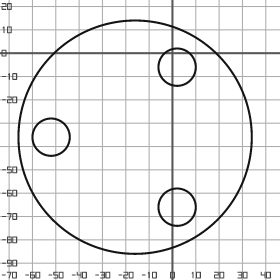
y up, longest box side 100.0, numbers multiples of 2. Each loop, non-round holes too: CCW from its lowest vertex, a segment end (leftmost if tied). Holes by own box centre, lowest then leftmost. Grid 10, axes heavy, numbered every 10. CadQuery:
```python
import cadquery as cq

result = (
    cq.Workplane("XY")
    .moveTo(-16.0, -36.0)
    .circle(50.0)
    .moveTo(2.0, -66.0)
    .circle(8.0)
    .moveTo(-52.0, -36.0)
    .circle(8.0)
    .moveTo(2.0, -6.0)
    .circle(8.0)
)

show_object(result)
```